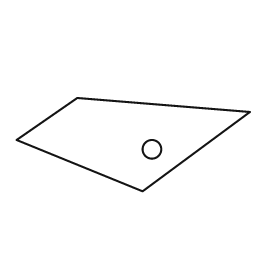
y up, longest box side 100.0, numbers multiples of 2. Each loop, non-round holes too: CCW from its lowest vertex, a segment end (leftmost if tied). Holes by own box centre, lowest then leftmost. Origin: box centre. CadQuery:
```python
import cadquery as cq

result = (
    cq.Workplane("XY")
    .moveTo(4.0, -20.0)
    .lineTo(50.0, 14.0)
    .lineTo(-24.0, 20.0)
    .lineTo(-50.0, 2.0)
    .close()
    .moveTo(8.0, -2.0)
    .circle(4.0)
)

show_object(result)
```